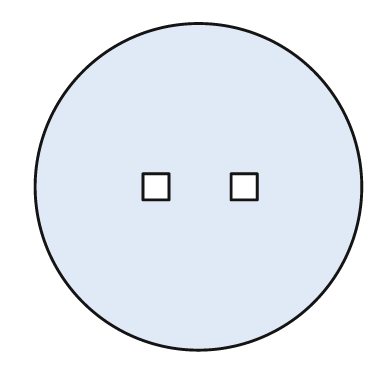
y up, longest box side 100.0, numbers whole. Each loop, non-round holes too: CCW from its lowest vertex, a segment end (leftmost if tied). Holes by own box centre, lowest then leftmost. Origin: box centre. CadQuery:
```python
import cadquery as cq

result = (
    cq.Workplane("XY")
    .moveTo(0.0, 0.0)
    .circle(50.0)
    .moveTo(-17.0, -4.0)
    .lineTo(-9.0, -4.0)
    .lineTo(-9.0, 4.0)
    .lineTo(-17.0, 4.0)
    .close()
    .moveTo(10.0, -4.0)
    .lineTo(18.0, -4.0)
    .lineTo(18.0, 4.0)
    .lineTo(10.0, 4.0)
    .close()
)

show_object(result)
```